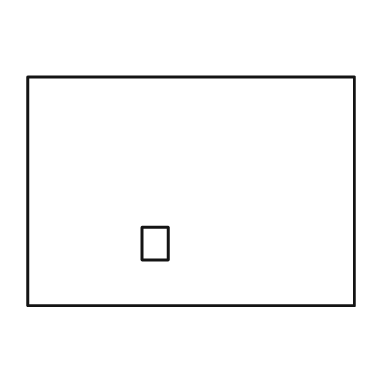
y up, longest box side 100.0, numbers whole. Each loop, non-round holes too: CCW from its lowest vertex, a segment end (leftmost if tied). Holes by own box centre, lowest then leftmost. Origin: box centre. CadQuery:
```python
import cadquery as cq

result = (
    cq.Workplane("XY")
    .moveTo(-50.0, -35.0)
    .lineTo(50.0, -35.0)
    .lineTo(50.0, 35.0)
    .lineTo(-50.0, 35.0)
    .close()
    .moveTo(-15.0, -21.0)
    .lineTo(-7.0, -21.0)
    .lineTo(-7.0, -11.0)
    .lineTo(-15.0, -11.0)
    .close()
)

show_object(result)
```